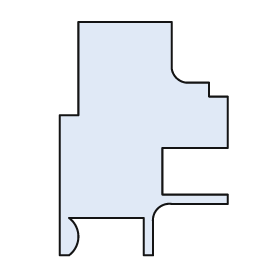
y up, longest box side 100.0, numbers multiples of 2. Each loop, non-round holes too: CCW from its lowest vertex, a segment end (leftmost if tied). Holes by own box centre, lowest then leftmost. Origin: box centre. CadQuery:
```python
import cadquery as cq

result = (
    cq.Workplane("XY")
    .moveTo(-36.0, -50.0)
    .lineTo(-32.0, -50.0)
    .threePointArc((-28.0, -42.0), (-32.0, -34.0))
    .lineTo(0.0, -34.0)
    .lineTo(0.0, -50.0)
    .lineTo(4.0, -50.0)
    .lineTo(4.0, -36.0)
    .threePointArc((6.0, -30.0), (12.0, -28.0))
    .lineTo(36.0, -28.0)
    .lineTo(36.0, -24.0)
    .lineTo(8.0, -24.0)
    .lineTo(8.0, -4.0)
    .lineTo(36.0, -4.0)
    .lineTo(36.0, 18.0)
    .lineTo(28.0, 18.0)
    .lineTo(28.0, 24.0)
    .lineTo(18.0, 24.0)
    .threePointArc((14.0, 26.0), (12.0, 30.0))
    .lineTo(12.0, 50.0)
    .lineTo(-28.0, 50.0)
    .lineTo(-28.0, 10.0)
    .lineTo(-36.0, 10.0)
    .close()
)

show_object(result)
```